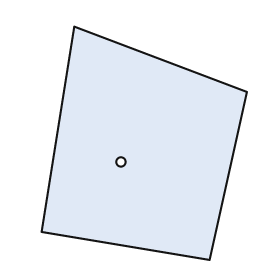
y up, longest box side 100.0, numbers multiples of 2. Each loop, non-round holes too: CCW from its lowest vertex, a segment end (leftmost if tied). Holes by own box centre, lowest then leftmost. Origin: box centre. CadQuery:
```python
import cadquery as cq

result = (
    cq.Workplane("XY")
    .moveTo(28.0, -50.0)
    .lineTo(44.0, 22.0)
    .lineTo(-30.0, 50.0)
    .lineTo(-44.0, -38.0)
    .close()
    .moveTo(-10.0, -8.0)
    .circle(2.0)
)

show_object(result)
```